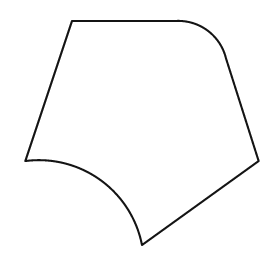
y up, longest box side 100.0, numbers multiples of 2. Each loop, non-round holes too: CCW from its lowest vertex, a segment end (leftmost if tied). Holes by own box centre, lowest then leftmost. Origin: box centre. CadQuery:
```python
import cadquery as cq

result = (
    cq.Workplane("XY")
    .moveTo(0.0, -48.0)
    .lineTo(50.0, -12.0)
    .lineTo(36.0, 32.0)
    .threePointArc((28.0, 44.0), (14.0, 48.0))
    .lineTo(-30.0, 48.0)
    .lineTo(-50.0, -12.0)
    .threePointArc((-18.0, -20.0), (0.0, -48.0))
    .close()
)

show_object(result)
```